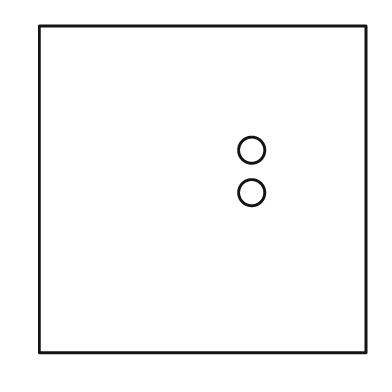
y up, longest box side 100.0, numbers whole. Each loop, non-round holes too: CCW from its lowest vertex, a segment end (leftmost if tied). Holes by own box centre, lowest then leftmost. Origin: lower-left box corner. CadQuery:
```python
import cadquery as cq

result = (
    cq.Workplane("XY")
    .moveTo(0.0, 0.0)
    .lineTo(100.0, 0.0)
    .lineTo(100.0, 100.0)
    .lineTo(0.0, 100.0)
    .close()
    .moveTo(65.0, 49.0)
    .circle(4.0)
    .moveTo(65.0, 62.0)
    .circle(4.0)
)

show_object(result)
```